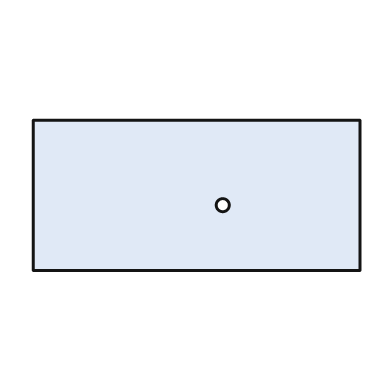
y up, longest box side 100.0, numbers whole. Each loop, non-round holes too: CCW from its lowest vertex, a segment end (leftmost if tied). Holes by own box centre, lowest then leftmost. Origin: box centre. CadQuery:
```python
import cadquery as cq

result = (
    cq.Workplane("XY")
    .moveTo(-50.0, -23.0)
    .lineTo(50.0, -23.0)
    .lineTo(50.0, 23.0)
    .lineTo(-50.0, 23.0)
    .close()
    .moveTo(8.0, -3.0)
    .circle(2.0)
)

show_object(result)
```